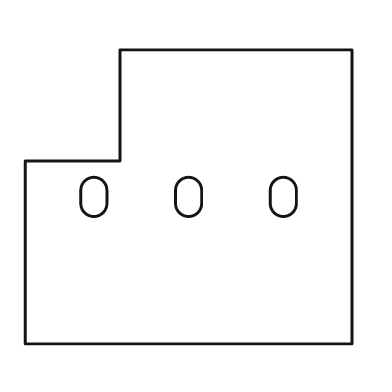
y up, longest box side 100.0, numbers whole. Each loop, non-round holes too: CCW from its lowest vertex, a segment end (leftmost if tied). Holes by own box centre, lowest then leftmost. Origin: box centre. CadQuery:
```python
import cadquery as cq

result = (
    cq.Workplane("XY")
    .moveTo(-50.0, -45.0)
    .lineTo(50.0, -45.0)
    .lineTo(50.0, 45.0)
    .lineTo(-21.0, 45.0)
    .lineTo(-21.0, 11.0)
    .lineTo(-50.0, 11.0)
    .close()
    .moveTo(-33.0, -2.0)
    .threePointArc((-29.0, -6.0), (-25.0, -2.0))
    .lineTo(-25.0, 2.0)
    .threePointArc((-29.0, 6.0), (-33.0, 2.0))
    .close()
    .moveTo(-4.0, -2.0)
    .threePointArc((0.0, -6.0), (4.0, -2.0))
    .lineTo(4.0, 2.0)
    .threePointArc((0.0, 6.0), (-4.0, 2.0))
    .close()
    .moveTo(25.0, -2.0)
    .threePointArc((29.0, -6.0), (33.0, -2.0))
    .lineTo(33.0, 2.0)
    .threePointArc((29.0, 6.0), (25.0, 2.0))
    .close()
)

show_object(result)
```